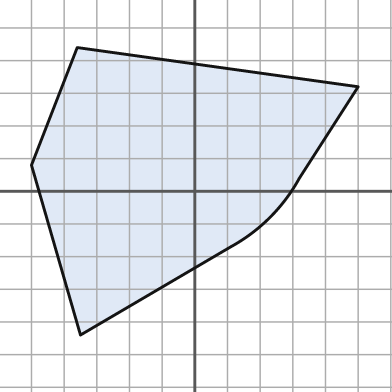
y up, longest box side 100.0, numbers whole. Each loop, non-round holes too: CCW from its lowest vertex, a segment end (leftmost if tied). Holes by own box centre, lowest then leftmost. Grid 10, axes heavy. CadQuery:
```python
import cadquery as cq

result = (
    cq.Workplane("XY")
    .moveTo(-35.0, -44.0)
    .lineTo(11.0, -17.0)
    .threePointArc((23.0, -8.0), (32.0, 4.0))
    .lineTo(50.0, 32.0)
    .lineTo(-36.0, 44.0)
    .lineTo(-50.0, 8.0)
    .close()
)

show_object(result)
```